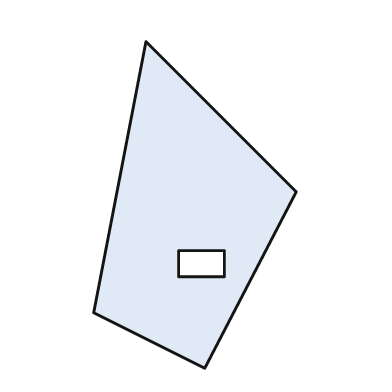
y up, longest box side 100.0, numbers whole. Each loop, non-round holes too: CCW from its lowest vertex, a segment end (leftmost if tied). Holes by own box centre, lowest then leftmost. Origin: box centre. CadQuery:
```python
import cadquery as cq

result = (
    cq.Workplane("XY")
    .moveTo(3.0, -50.0)
    .lineTo(31.0, 4.0)
    .lineTo(-15.0, 50.0)
    .lineTo(-31.0, -33.0)
    .close()
    .moveTo(-5.0, -22.0)
    .lineTo(9.0, -22.0)
    .lineTo(9.0, -14.0)
    .lineTo(-5.0, -14.0)
    .close()
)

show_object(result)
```